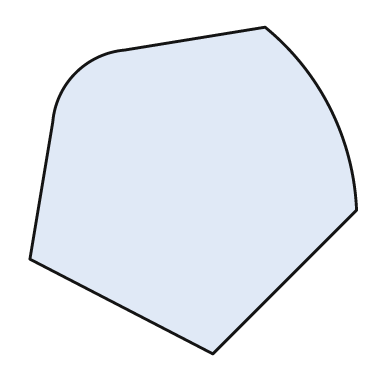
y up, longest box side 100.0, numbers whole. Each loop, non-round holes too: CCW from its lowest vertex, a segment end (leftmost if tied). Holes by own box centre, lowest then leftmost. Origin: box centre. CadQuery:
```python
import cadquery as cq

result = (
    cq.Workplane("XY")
    .moveTo(6.0, -50.0)
    .lineTo(50.0, -6.0)
    .threePointArc((42.0, 25.0), (22.0, 50.0))
    .lineTo(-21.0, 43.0)
    .threePointArc((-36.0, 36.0), (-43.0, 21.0))
    .lineTo(-50.0, -21.0)
    .close()
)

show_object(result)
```